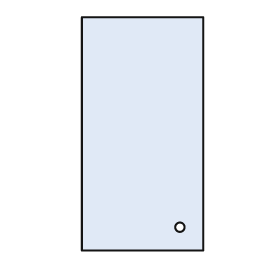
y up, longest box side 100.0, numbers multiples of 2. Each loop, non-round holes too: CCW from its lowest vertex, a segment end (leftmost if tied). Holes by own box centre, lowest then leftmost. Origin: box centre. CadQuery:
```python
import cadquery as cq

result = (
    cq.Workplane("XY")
    .moveTo(-26.0, -50.0)
    .lineTo(26.0, -50.0)
    .lineTo(26.0, 50.0)
    .lineTo(-26.0, 50.0)
    .close()
    .moveTo(16.0, -40.0)
    .circle(2.0)
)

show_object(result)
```